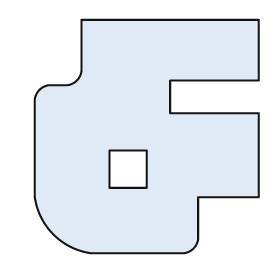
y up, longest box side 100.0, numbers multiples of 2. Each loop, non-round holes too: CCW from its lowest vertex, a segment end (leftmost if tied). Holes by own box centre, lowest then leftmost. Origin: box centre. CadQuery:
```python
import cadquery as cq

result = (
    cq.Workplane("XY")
    .moveTo(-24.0, -50.0)
    .lineTo(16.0, -50.0)
    .threePointArc((20.0, -48.0), (22.0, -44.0))
    .lineTo(22.0, -26.0)
    .lineTo(48.0, -26.0)
    .lineTo(48.0, 10.0)
    .lineTo(10.0, 10.0)
    .lineTo(10.0, 24.0)
    .lineTo(48.0, 24.0)
    .lineTo(48.0, 50.0)
    .lineTo(-28.0, 50.0)
    .lineTo(-28.0, 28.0)
    .threePointArc((-30.0, 24.0), (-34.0, 22.0))
    .lineTo(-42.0, 22.0)
    .threePointArc((-46.0, 20.0), (-48.0, 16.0))
    .lineTo(-48.0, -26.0)
    .threePointArc((-40.0, -42.0), (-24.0, -50.0))
    .close()
    .moveTo(-16.0, -22.0)
    .lineTo(0.0, -22.0)
    .lineTo(0.0, -6.0)
    .lineTo(-16.0, -6.0)
    .close()
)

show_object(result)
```